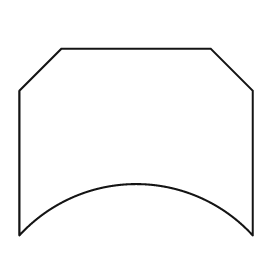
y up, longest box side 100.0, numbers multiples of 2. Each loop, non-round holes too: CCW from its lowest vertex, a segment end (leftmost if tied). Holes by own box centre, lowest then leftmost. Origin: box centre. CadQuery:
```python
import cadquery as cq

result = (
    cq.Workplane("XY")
    .moveTo(-50.0, -40.0)
    .threePointArc((0.0, -18.0), (50.0, -40.0))
    .lineTo(50.0, 22.0)
    .lineTo(32.0, 40.0)
    .lineTo(-32.0, 40.0)
    .lineTo(-50.0, 22.0)
    .close()
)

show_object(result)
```